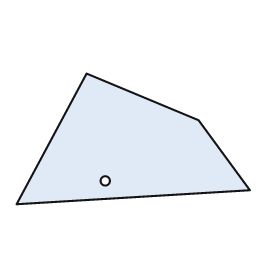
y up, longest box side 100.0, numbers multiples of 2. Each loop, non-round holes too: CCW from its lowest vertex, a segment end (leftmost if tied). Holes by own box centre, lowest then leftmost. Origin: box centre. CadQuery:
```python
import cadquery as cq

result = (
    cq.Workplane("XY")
    .moveTo(-50.0, -28.0)
    .lineTo(50.0, -22.0)
    .lineTo(28.0, 8.0)
    .lineTo(-20.0, 28.0)
    .close()
    .moveTo(-12.0, -18.0)
    .circle(2.0)
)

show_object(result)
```